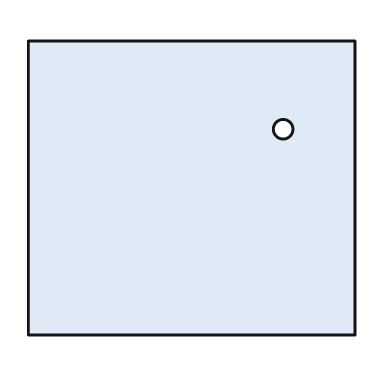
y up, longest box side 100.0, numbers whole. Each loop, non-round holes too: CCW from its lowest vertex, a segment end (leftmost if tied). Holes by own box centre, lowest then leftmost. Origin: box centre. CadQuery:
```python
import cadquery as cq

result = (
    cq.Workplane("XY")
    .moveTo(-50.0, -45.0)
    .lineTo(50.0, -45.0)
    .lineTo(50.0, 45.0)
    .lineTo(-50.0, 45.0)
    .close()
    .moveTo(28.0, 18.0)
    .circle(3.0)
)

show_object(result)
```